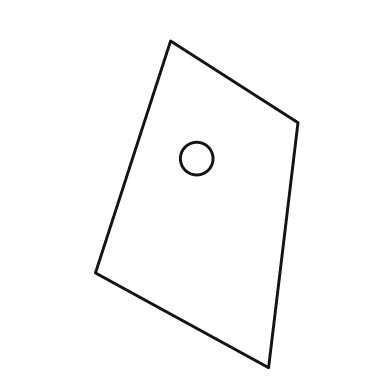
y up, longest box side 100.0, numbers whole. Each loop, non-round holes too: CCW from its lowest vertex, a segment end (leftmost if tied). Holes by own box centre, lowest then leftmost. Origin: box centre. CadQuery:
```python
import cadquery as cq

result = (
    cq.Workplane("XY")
    .moveTo(22.0, -50.0)
    .lineTo(31.0, 25.0)
    .lineTo(-8.0, 50.0)
    .lineTo(-31.0, -21.0)
    .close()
    .moveTo(0.0, 14.0)
    .circle(5.0)
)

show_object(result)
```